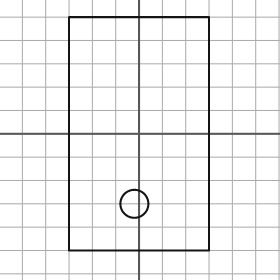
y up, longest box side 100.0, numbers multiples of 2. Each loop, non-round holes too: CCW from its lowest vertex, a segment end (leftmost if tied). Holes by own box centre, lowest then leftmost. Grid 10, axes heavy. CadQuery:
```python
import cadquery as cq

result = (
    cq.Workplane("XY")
    .moveTo(-30.0, -50.0)
    .lineTo(30.0, -50.0)
    .lineTo(30.0, 50.0)
    .lineTo(-30.0, 50.0)
    .close()
    .moveTo(-2.0, -30.0)
    .circle(6.0)
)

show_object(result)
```